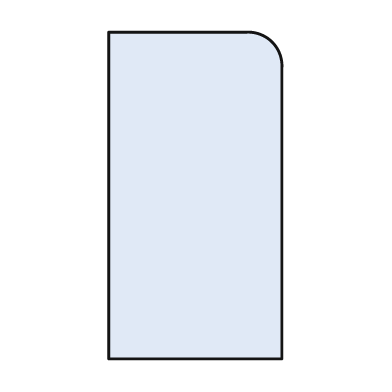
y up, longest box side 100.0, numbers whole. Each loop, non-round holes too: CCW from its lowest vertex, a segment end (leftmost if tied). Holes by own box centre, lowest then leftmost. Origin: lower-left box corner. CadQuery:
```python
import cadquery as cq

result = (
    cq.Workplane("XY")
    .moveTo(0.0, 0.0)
    .lineTo(53.0, 0.0)
    .lineTo(53.0, 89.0)
    .threePointArc((50.0, 97.0), (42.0, 100.0))
    .lineTo(0.0, 100.0)
    .close()
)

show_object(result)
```